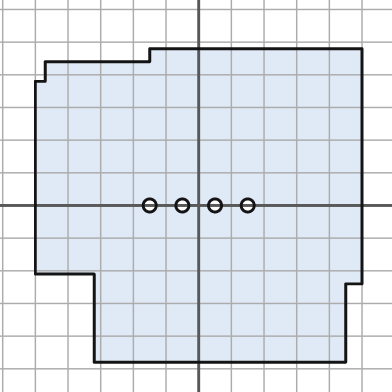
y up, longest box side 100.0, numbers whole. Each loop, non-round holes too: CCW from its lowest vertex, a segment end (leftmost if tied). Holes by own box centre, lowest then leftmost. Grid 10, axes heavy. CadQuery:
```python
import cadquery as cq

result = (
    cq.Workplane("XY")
    .moveTo(-32.0, -48.0)
    .lineTo(45.0, -48.0)
    .lineTo(45.0, -24.0)
    .lineTo(50.0, -24.0)
    .lineTo(50.0, 48.0)
    .lineTo(-15.0, 48.0)
    .lineTo(-15.0, 44.0)
    .lineTo(-47.0, 44.0)
    .lineTo(-47.0, 38.0)
    .lineTo(-50.0, 38.0)
    .lineTo(-50.0, -21.0)
    .lineTo(-32.0, -21.0)
    .close()
    .moveTo(-15.0, 0.0)
    .circle(2.0)
    .moveTo(-5.0, 0.0)
    .circle(2.0)
    .moveTo(5.0, 0.0)
    .circle(2.0)
    .moveTo(15.0, 0.0)
    .circle(2.0)
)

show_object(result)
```